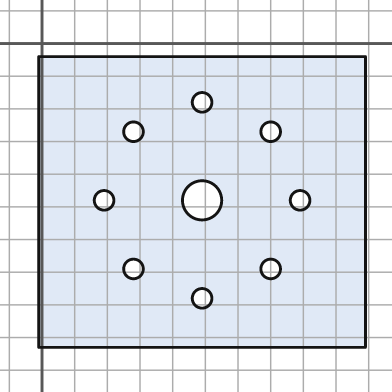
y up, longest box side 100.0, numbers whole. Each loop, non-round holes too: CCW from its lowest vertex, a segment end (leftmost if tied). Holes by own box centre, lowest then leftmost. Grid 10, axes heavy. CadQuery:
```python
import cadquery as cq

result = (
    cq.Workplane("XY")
    .moveTo(-1.0, -93.0)
    .lineTo(99.0, -93.0)
    .lineTo(99.0, -4.0)
    .lineTo(-1.0, -4.0)
    .close()
    .moveTo(49.0, -78.0)
    .circle(3.0)
    .moveTo(28.0, -69.0)
    .circle(3.0)
    .moveTo(70.0, -69.0)
    .circle(3.0)
    .moveTo(19.0, -48.0)
    .circle(3.0)
    .moveTo(49.0, -48.0)
    .circle(6.0)
    .moveTo(79.0, -48.0)
    .circle(3.0)
    .moveTo(28.0, -27.0)
    .circle(3.0)
    .moveTo(70.0, -27.0)
    .circle(3.0)
    .moveTo(49.0, -18.0)
    .circle(3.0)
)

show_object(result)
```